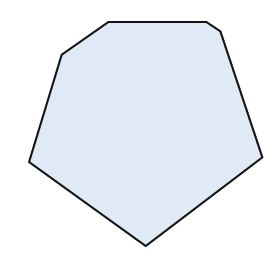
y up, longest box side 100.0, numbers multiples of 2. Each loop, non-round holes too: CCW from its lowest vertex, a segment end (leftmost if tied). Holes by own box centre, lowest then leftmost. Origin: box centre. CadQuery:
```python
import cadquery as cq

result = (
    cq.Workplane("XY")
    .moveTo(0.0, -48.0)
    .lineTo(50.0, -10.0)
    .lineTo(32.0, 44.0)
    .lineTo(26.0, 48.0)
    .lineTo(-16.0, 48.0)
    .lineTo(-36.0, 34.0)
    .lineTo(-50.0, -12.0)
    .close()
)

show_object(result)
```